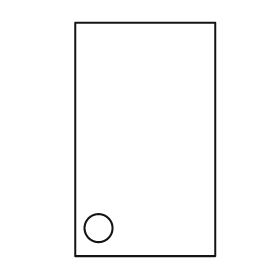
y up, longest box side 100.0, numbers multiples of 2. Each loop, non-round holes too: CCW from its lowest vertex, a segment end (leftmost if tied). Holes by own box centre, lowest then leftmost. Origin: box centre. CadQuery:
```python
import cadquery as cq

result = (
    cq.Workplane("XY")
    .moveTo(-30.0, -50.0)
    .lineTo(30.0, -50.0)
    .lineTo(30.0, 50.0)
    .lineTo(-30.0, 50.0)
    .close()
    .moveTo(-20.0, -38.0)
    .circle(6.0)
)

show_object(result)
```